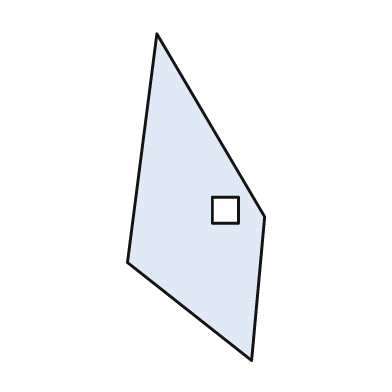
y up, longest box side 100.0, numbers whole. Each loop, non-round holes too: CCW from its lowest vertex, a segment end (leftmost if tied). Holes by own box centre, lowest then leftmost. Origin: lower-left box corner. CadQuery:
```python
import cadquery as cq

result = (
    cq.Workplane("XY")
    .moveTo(38.0, 0.0)
    .lineTo(42.0, 44.0)
    .lineTo(9.0, 100.0)
    .lineTo(0.0, 30.0)
    .close()
    .moveTo(26.0, 42.0)
    .lineTo(34.0, 42.0)
    .lineTo(34.0, 50.0)
    .lineTo(26.0, 50.0)
    .close()
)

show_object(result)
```